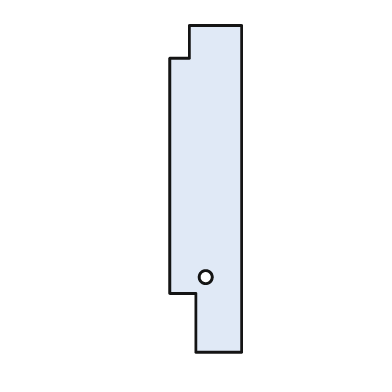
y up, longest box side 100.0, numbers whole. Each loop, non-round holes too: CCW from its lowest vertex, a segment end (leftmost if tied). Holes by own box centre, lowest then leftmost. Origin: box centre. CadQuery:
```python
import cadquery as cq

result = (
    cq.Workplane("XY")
    .moveTo(-3.0, -50.0)
    .lineTo(11.0, -50.0)
    .lineTo(11.0, 50.0)
    .lineTo(-5.0, 50.0)
    .lineTo(-5.0, 40.0)
    .lineTo(-11.0, 40.0)
    .lineTo(-11.0, -32.0)
    .lineTo(-3.0, -32.0)
    .close()
    .moveTo(0.0, -27.0)
    .circle(2.0)
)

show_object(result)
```